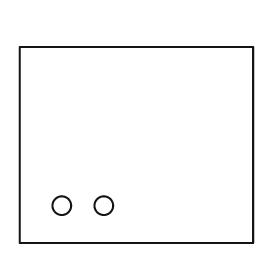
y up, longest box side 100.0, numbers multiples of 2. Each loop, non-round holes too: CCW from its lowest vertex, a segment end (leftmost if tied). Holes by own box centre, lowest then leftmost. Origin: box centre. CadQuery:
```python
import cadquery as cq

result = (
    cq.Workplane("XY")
    .moveTo(-50.0, -42.0)
    .lineTo(50.0, -42.0)
    .lineTo(50.0, 42.0)
    .lineTo(-50.0, 42.0)
    .close()
    .moveTo(-32.0, -26.0)
    .circle(4.0)
    .moveTo(-14.0, -26.0)
    .circle(4.0)
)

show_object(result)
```